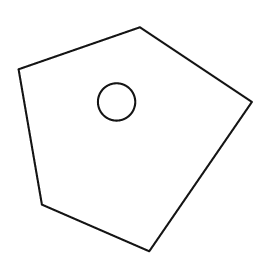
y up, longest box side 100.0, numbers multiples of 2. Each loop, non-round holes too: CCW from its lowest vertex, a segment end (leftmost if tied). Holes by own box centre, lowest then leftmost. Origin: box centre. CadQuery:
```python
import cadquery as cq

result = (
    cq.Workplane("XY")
    .moveTo(6.0, -48.0)
    .lineTo(50.0, 16.0)
    .lineTo(2.0, 48.0)
    .lineTo(-50.0, 30.0)
    .lineTo(-40.0, -28.0)
    .close()
    .moveTo(-8.0, 16.0)
    .circle(8.0)
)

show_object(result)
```